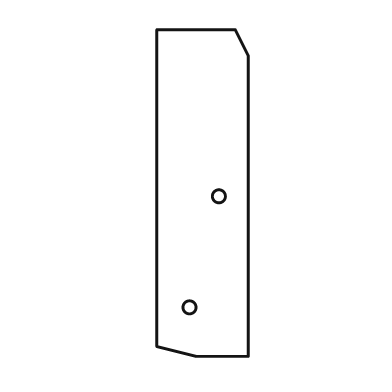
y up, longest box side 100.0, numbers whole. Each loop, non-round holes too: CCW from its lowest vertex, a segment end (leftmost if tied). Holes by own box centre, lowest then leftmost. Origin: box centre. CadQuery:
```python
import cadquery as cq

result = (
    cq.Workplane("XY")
    .moveTo(-2.0, -50.0)
    .lineTo(14.0, -50.0)
    .lineTo(14.0, 42.0)
    .lineTo(10.0, 50.0)
    .lineTo(-14.0, 50.0)
    .lineTo(-14.0, -47.0)
    .close()
    .moveTo(-4.0, -35.0)
    .circle(2.0)
    .moveTo(5.0, -1.0)
    .circle(2.0)
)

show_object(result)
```